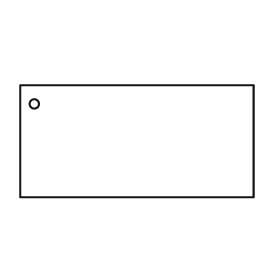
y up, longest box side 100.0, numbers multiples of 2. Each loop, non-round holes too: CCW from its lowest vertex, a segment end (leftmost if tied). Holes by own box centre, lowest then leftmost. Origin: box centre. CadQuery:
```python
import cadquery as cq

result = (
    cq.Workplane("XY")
    .moveTo(-50.0, -24.0)
    .lineTo(50.0, -24.0)
    .lineTo(50.0, 24.0)
    .lineTo(-50.0, 24.0)
    .close()
    .moveTo(-44.0, 16.0)
    .circle(2.0)
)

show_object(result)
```